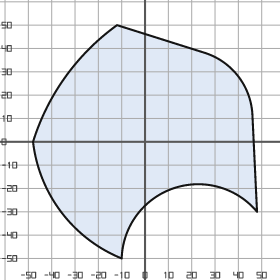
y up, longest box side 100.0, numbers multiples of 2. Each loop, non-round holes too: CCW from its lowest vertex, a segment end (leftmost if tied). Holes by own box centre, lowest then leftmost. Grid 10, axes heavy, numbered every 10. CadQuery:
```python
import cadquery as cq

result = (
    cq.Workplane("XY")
    .moveTo(-10.0, -50.0)
    .threePointArc((12.0, -20.0), (48.0, -30.0))
    .lineTo(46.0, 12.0)
    .threePointArc((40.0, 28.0), (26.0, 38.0))
    .lineTo(-12.0, 50.0)
    .threePointArc((-34.0, 28.0), (-48.0, 0.0))
    .threePointArc((-36.0, -30.0), (-10.0, -50.0))
    .close()
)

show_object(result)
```